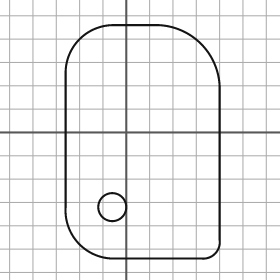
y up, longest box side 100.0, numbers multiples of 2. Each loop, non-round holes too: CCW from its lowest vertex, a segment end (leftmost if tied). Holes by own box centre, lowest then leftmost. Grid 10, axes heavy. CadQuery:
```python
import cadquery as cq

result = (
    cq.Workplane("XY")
    .moveTo(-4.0, -54.0)
    .lineTo(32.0, -54.0)
    .threePointArc((38.0, -52.0), (40.0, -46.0))
    .lineTo(40.0, 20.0)
    .threePointArc((32.0, 38.0), (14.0, 46.0))
    .lineTo(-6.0, 46.0)
    .threePointArc((-20.0, 40.0), (-26.0, 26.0))
    .lineTo(-26.0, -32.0)
    .threePointArc((-20.0, -48.0), (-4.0, -54.0))
    .close()
    .moveTo(-6.0, -32.0)
    .circle(6.0)
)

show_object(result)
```